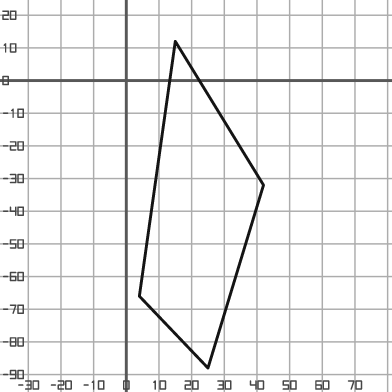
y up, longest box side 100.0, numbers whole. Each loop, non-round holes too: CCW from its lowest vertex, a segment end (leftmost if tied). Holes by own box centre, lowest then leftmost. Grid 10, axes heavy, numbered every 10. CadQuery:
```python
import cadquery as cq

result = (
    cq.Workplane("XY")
    .moveTo(25.0, -88.0)
    .lineTo(42.0, -32.0)
    .lineTo(15.0, 12.0)
    .lineTo(4.0, -66.0)
    .close()
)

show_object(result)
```